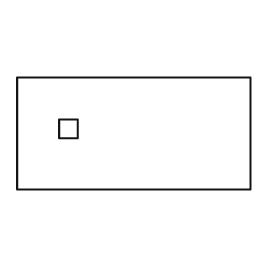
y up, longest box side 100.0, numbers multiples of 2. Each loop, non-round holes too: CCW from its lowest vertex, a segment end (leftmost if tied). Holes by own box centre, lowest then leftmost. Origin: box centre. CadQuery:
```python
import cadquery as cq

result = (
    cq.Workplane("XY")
    .moveTo(-50.0, -24.0)
    .lineTo(50.0, -24.0)
    .lineTo(50.0, 24.0)
    .lineTo(-50.0, 24.0)
    .close()
    .moveTo(-32.0, -2.0)
    .lineTo(-24.0, -2.0)
    .lineTo(-24.0, 6.0)
    .lineTo(-32.0, 6.0)
    .close()
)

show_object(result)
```